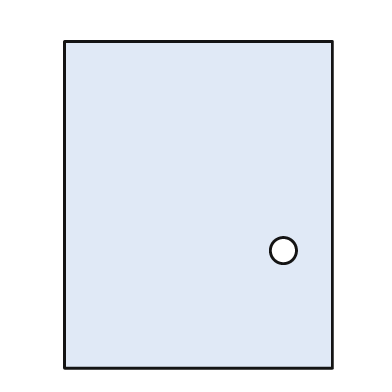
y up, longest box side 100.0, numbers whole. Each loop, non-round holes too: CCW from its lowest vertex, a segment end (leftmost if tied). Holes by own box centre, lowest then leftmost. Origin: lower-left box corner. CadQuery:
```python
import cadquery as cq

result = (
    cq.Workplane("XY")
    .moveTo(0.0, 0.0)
    .lineTo(82.0, 0.0)
    .lineTo(82.0, 100.0)
    .lineTo(0.0, 100.0)
    .close()
    .moveTo(67.0, 36.0)
    .circle(4.0)
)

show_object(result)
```